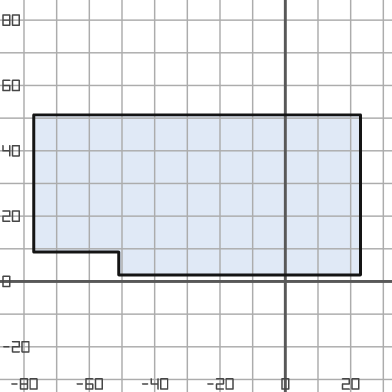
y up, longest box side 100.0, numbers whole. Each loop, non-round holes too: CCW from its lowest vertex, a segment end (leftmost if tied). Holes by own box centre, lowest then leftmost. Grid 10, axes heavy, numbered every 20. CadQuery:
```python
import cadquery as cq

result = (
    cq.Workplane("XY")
    .moveTo(-51.0, 2.0)
    .lineTo(23.0, 2.0)
    .lineTo(23.0, 51.0)
    .lineTo(-77.0, 51.0)
    .lineTo(-77.0, 9.0)
    .lineTo(-51.0, 9.0)
    .close()
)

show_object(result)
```